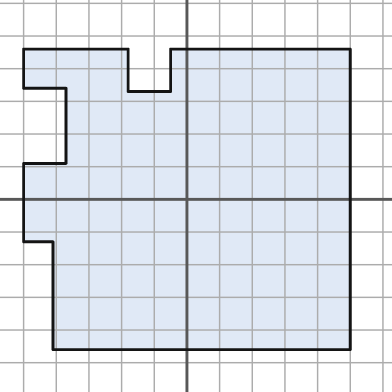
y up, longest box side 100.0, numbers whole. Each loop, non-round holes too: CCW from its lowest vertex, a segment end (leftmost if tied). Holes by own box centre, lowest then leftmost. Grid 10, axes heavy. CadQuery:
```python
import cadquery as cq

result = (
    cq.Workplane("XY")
    .moveTo(-41.0, -46.0)
    .lineTo(50.0, -46.0)
    .lineTo(50.0, 46.0)
    .lineTo(-5.0, 46.0)
    .lineTo(-5.0, 33.0)
    .lineTo(-18.0, 33.0)
    .lineTo(-18.0, 46.0)
    .lineTo(-50.0, 46.0)
    .lineTo(-50.0, 34.0)
    .lineTo(-37.0, 34.0)
    .lineTo(-37.0, 11.0)
    .lineTo(-50.0, 11.0)
    .lineTo(-50.0, -13.0)
    .lineTo(-41.0, -13.0)
    .close()
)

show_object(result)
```